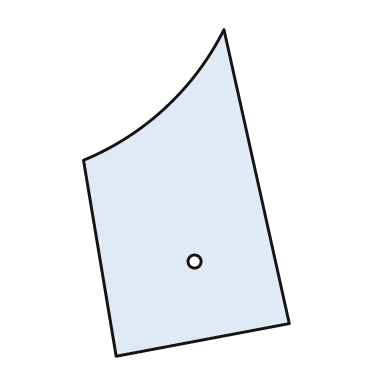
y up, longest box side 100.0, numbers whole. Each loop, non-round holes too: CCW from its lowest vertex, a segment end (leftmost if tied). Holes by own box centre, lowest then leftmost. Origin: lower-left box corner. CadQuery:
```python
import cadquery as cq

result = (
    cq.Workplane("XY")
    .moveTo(10.0, 0.0)
    .lineTo(63.0, 10.0)
    .lineTo(43.0, 100.0)
    .threePointArc((25.0, 76.0), (0.0, 60.0))
    .close()
    .moveTo(34.0, 29.0)
    .circle(2.0)
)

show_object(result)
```